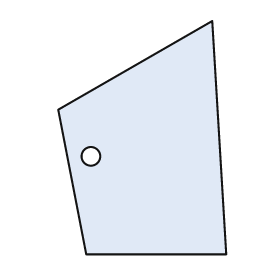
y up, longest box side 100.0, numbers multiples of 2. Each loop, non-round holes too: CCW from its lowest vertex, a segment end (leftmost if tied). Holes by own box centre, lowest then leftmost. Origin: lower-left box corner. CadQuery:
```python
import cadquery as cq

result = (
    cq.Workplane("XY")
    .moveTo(12.0, 0.0)
    .lineTo(72.0, 0.0)
    .lineTo(66.0, 100.0)
    .lineTo(0.0, 62.0)
    .close()
    .moveTo(14.0, 42.0)
    .circle(4.0)
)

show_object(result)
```